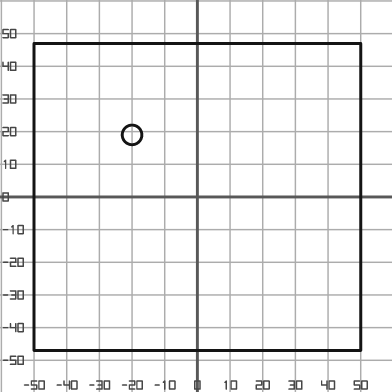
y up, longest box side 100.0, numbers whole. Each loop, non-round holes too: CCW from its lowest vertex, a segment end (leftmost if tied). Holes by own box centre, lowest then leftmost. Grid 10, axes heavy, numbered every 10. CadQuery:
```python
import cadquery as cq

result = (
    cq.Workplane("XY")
    .moveTo(-50.0, -47.0)
    .lineTo(50.0, -47.0)
    .lineTo(50.0, 47.0)
    .lineTo(-50.0, 47.0)
    .close()
    .moveTo(-20.0, 19.0)
    .circle(3.0)
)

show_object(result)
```